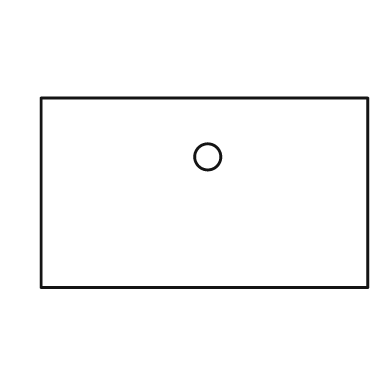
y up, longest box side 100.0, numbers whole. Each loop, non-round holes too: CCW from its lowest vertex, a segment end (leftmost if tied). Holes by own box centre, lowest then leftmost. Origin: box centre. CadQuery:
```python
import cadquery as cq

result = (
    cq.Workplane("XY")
    .moveTo(-50.0, -29.0)
    .lineTo(50.0, -29.0)
    .lineTo(50.0, 29.0)
    .lineTo(-50.0, 29.0)
    .close()
    .moveTo(1.0, 11.0)
    .circle(4.0)
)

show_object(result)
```